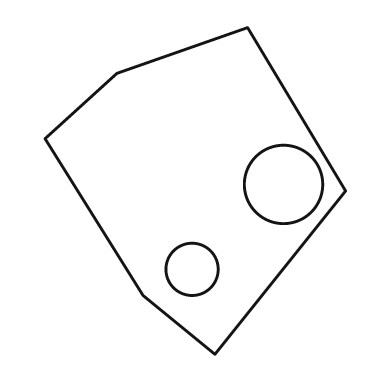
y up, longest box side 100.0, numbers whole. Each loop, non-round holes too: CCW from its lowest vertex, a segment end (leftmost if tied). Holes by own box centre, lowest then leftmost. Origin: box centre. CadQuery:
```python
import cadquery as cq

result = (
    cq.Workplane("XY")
    .moveTo(6.0, -50.0)
    .lineTo(46.0, 0.0)
    .lineTo(16.0, 50.0)
    .lineTo(-24.0, 36.0)
    .lineTo(-46.0, 16.0)
    .lineTo(-16.0, -32.0)
    .close()
    .moveTo(-1.0, -24.0)
    .circle(8.0)
    .moveTo(27.0, 2.0)
    .circle(12.0)
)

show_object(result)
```